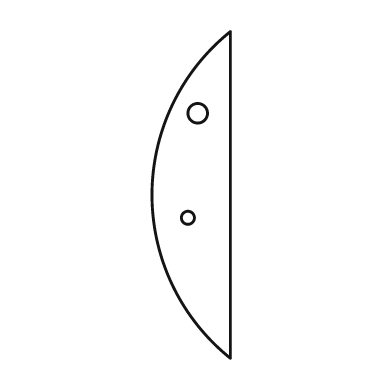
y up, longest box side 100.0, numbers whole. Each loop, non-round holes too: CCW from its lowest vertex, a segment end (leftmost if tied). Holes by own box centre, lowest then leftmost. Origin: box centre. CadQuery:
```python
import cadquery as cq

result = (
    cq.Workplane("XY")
    .moveTo(12.0, -50.0)
    .lineTo(12.0, 50.0)
    .threePointArc((-12.0, 0.0), (12.0, -50.0))
    .close()
    .moveTo(-1.0, -7.0)
    .circle(2.0)
    .moveTo(2.0, 25.0)
    .circle(3.0)
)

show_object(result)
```